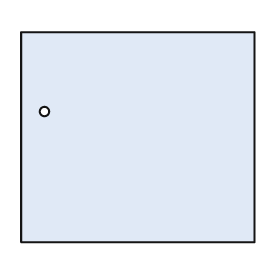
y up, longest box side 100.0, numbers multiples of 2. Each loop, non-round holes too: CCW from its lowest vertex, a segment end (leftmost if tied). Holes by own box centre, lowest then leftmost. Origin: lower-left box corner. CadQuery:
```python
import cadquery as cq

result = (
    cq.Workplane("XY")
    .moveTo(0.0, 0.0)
    .lineTo(100.0, 0.0)
    .lineTo(100.0, 90.0)
    .lineTo(0.0, 90.0)
    .close()
    .moveTo(10.0, 56.0)
    .circle(2.0)
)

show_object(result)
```